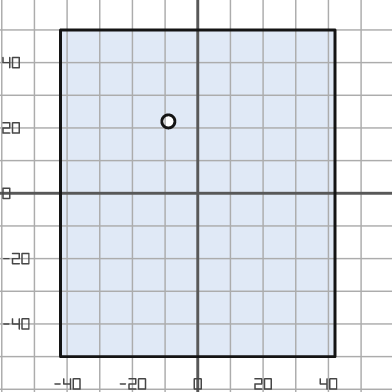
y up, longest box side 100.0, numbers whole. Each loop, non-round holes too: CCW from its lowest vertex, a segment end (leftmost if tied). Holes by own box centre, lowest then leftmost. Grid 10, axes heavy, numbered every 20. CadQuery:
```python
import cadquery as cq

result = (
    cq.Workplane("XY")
    .moveTo(-42.0, -50.0)
    .lineTo(42.0, -50.0)
    .lineTo(42.0, 50.0)
    .lineTo(-42.0, 50.0)
    .close()
    .moveTo(-9.0, 22.0)
    .circle(2.0)
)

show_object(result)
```